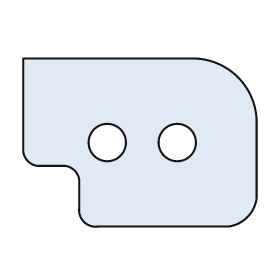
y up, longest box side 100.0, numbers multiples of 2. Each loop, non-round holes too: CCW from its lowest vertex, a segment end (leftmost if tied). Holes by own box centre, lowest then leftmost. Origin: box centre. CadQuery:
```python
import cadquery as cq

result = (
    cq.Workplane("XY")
    .moveTo(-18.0, -36.0)
    .lineTo(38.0, -36.0)
    .threePointArc((46.0, -32.0), (50.0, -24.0))
    .lineTo(50.0, 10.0)
    .threePointArc((42.0, 28.0), (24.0, 36.0))
    .lineTo(-50.0, 36.0)
    .lineTo(-50.0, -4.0)
    .threePointArc((-48.0, -8.0), (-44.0, -10.0))
    .lineTo(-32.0, -10.0)
    .threePointArc((-28.0, -12.0), (-26.0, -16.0))
    .lineTo(-26.0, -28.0)
    .threePointArc((-24.0, -34.0), (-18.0, -36.0))
    .close()
    .moveTo(-14.0, 0.0)
    .circle(8.0)
    .moveTo(16.0, 0.0)
    .circle(8.0)
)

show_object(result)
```